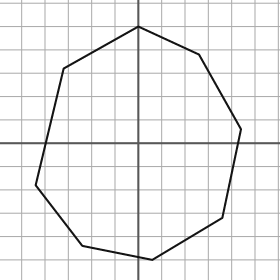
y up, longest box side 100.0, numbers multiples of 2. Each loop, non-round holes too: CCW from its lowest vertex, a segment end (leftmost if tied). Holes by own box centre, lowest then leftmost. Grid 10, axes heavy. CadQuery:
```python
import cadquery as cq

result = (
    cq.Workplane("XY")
    .moveTo(6.0, -50.0)
    .lineTo(36.0, -32.0)
    .lineTo(44.0, 6.0)
    .lineTo(26.0, 38.0)
    .lineTo(0.0, 50.0)
    .lineTo(-32.0, 32.0)
    .lineTo(-44.0, -18.0)
    .lineTo(-24.0, -44.0)
    .close()
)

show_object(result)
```